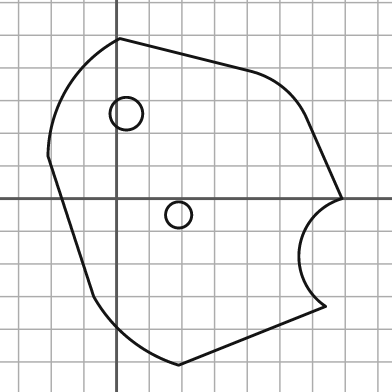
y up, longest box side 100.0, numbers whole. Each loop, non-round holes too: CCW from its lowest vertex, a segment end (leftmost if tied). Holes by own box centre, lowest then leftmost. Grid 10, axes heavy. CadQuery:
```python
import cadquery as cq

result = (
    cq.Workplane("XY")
    .moveTo(19.0, -51.0)
    .lineTo(64.0, -33.0)
    .threePointArc((56.0, -15.0), (69.0, 0.0))
    .lineTo(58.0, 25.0)
    .threePointArc((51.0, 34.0), (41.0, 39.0))
    .lineTo(1.0, 49.0)
    .threePointArc((-15.0, 34.0), (-21.0, 13.0))
    .lineTo(-7.0, -30.0)
    .threePointArc((4.0, -43.0), (19.0, -51.0))
    .close()
    .moveTo(19.0, -5.0)
    .circle(4.0)
    .moveTo(3.0, 26.0)
    .circle(5.0)
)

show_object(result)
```